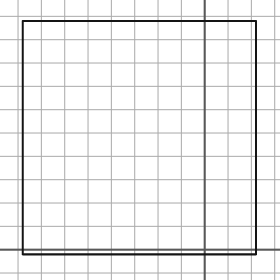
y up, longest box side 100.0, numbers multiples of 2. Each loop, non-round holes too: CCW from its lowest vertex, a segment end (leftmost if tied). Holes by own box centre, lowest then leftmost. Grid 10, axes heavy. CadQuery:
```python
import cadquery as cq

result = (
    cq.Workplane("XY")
    .moveTo(-78.0, -2.0)
    .lineTo(22.0, -2.0)
    .lineTo(22.0, 98.0)
    .lineTo(-78.0, 98.0)
    .close()
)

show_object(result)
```